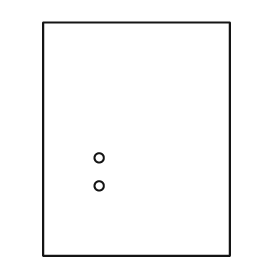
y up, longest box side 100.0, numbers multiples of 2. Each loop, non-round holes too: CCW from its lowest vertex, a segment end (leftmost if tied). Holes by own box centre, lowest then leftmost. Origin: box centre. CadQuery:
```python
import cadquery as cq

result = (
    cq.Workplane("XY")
    .moveTo(-40.0, -50.0)
    .lineTo(40.0, -50.0)
    .lineTo(40.0, 50.0)
    .lineTo(-40.0, 50.0)
    .close()
    .moveTo(-16.0, -20.0)
    .circle(2.0)
    .moveTo(-16.0, -8.0)
    .circle(2.0)
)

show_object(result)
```